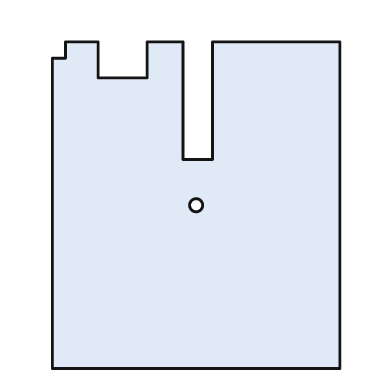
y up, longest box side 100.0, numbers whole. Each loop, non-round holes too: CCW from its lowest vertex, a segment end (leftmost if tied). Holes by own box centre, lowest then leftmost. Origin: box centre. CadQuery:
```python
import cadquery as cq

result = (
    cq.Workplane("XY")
    .moveTo(-44.0, -50.0)
    .lineTo(44.0, -50.0)
    .lineTo(44.0, 50.0)
    .lineTo(5.0, 50.0)
    .lineTo(5.0, 14.0)
    .lineTo(-4.0, 14.0)
    .lineTo(-4.0, 50.0)
    .lineTo(-15.0, 50.0)
    .lineTo(-15.0, 39.0)
    .lineTo(-30.0, 39.0)
    .lineTo(-30.0, 50.0)
    .lineTo(-40.0, 50.0)
    .lineTo(-40.0, 45.0)
    .lineTo(-44.0, 45.0)
    .close()
    .moveTo(0.0, 0.0)
    .circle(2.0)
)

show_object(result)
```